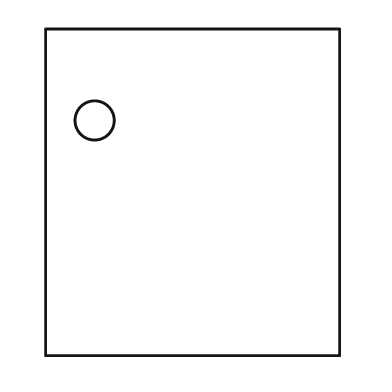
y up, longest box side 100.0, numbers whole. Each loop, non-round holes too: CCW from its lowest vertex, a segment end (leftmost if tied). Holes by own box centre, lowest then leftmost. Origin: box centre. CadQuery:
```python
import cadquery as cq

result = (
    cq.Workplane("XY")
    .moveTo(-45.0, -50.0)
    .lineTo(45.0, -50.0)
    .lineTo(45.0, 50.0)
    .lineTo(-45.0, 50.0)
    .close()
    .moveTo(-30.0, 22.0)
    .circle(6.0)
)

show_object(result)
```